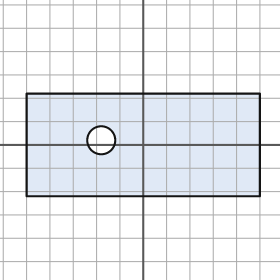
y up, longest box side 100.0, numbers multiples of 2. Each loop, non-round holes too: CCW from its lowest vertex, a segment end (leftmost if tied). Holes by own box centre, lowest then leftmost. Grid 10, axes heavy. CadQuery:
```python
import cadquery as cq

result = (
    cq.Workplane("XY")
    .moveTo(-50.0, -22.0)
    .lineTo(50.0, -22.0)
    .lineTo(50.0, 22.0)
    .lineTo(-50.0, 22.0)
    .close()
    .moveTo(-18.0, 2.0)
    .circle(6.0)
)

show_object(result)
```